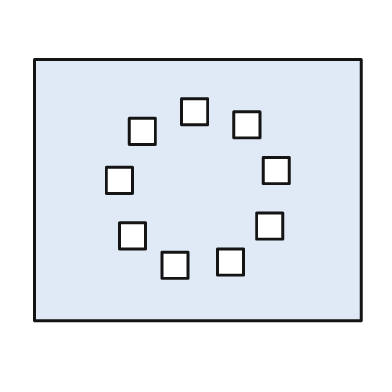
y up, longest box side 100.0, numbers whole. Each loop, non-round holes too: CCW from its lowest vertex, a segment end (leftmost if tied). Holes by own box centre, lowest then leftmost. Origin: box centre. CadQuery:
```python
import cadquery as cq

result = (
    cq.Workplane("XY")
    .moveTo(-50.0, -40.0)
    .lineTo(50.0, -40.0)
    .lineTo(50.0, 40.0)
    .lineTo(-50.0, 40.0)
    .close()
    .moveTo(-11.0, -27.0)
    .lineTo(-3.0, -27.0)
    .lineTo(-3.0, -19.0)
    .lineTo(-11.0, -19.0)
    .close()
    .moveTo(6.0, -26.0)
    .lineTo(14.0, -26.0)
    .lineTo(14.0, -18.0)
    .lineTo(6.0, -18.0)
    .close()
    .moveTo(-24.0, -18.0)
    .lineTo(-16.0, -18.0)
    .lineTo(-16.0, -10.0)
    .lineTo(-24.0, -10.0)
    .close()
    .moveTo(18.0, -15.0)
    .lineTo(26.0, -15.0)
    .lineTo(26.0, -7.0)
    .lineTo(18.0, -7.0)
    .close()
    .moveTo(-28.0, -1.0)
    .lineTo(-20.0, -1.0)
    .lineTo(-20.0, 7.0)
    .lineTo(-28.0, 7.0)
    .close()
    .moveTo(20.0, 2.0)
    .lineTo(28.0, 2.0)
    .lineTo(28.0, 10.0)
    .lineTo(20.0, 10.0)
    .close()
    .moveTo(-21.0, 14.0)
    .lineTo(-13.0, 14.0)
    .lineTo(-13.0, 22.0)
    .lineTo(-21.0, 22.0)
    .close()
    .moveTo(11.0, 16.0)
    .lineTo(19.0, 16.0)
    .lineTo(19.0, 24.0)
    .lineTo(11.0, 24.0)
    .close()
    .moveTo(-5.0, 20.0)
    .lineTo(3.0, 20.0)
    .lineTo(3.0, 28.0)
    .lineTo(-5.0, 28.0)
    .close()
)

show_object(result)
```